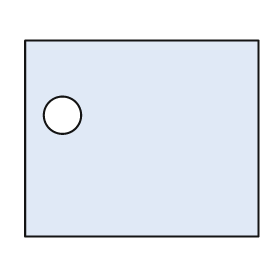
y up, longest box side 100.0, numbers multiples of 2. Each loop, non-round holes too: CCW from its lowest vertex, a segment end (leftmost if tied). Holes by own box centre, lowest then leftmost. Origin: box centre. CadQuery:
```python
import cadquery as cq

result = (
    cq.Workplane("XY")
    .moveTo(-50.0, -42.0)
    .lineTo(50.0, -42.0)
    .lineTo(50.0, 42.0)
    .lineTo(-50.0, 42.0)
    .close()
    .moveTo(-34.0, 10.0)
    .circle(8.0)
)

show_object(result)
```